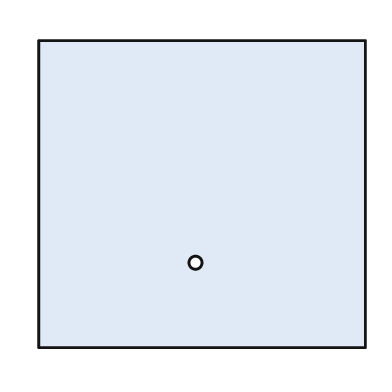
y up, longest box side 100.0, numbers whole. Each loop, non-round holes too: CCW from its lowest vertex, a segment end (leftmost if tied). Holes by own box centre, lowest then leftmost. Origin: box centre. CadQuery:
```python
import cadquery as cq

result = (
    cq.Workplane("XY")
    .moveTo(-50.0, -47.0)
    .lineTo(50.0, -47.0)
    .lineTo(50.0, 47.0)
    .lineTo(-50.0, 47.0)
    .close()
    .moveTo(-2.0, -21.0)
    .circle(2.0)
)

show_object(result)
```